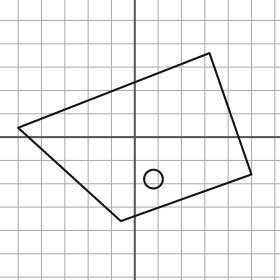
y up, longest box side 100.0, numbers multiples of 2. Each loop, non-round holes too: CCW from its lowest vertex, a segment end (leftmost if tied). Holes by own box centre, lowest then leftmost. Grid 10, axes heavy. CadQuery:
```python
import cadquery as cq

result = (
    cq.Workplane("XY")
    .moveTo(-6.0, -36.0)
    .lineTo(50.0, -16.0)
    .lineTo(32.0, 36.0)
    .lineTo(-50.0, 4.0)
    .close()
    .moveTo(8.0, -18.0)
    .circle(4.0)
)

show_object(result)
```